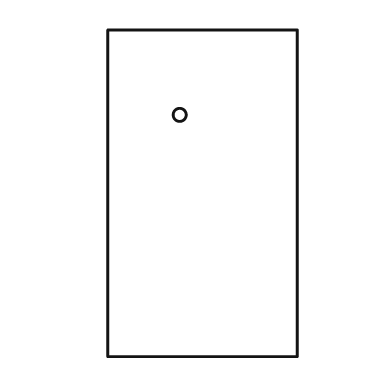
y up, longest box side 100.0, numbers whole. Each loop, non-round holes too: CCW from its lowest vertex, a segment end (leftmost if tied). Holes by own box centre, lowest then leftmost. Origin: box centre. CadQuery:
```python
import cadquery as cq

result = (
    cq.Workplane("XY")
    .moveTo(-29.0, -50.0)
    .lineTo(29.0, -50.0)
    .lineTo(29.0, 50.0)
    .lineTo(-29.0, 50.0)
    .close()
    .moveTo(-7.0, 24.0)
    .circle(2.0)
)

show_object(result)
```